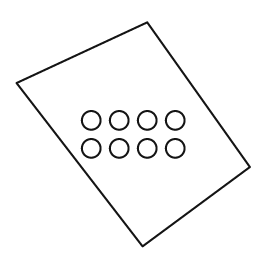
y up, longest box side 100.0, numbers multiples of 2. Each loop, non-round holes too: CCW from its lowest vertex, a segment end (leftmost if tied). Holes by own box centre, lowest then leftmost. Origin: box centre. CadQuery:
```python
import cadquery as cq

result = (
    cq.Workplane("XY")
    .moveTo(4.0, -48.0)
    .lineTo(50.0, -14.0)
    .lineTo(6.0, 48.0)
    .lineTo(-50.0, 22.0)
    .close()
    .moveTo(-18.0, -6.0)
    .circle(4.0)
    .moveTo(-6.0, -6.0)
    .circle(4.0)
    .moveTo(6.0, -6.0)
    .circle(4.0)
    .moveTo(18.0, -6.0)
    .circle(4.0)
    .moveTo(-18.0, 6.0)
    .circle(4.0)
    .moveTo(-6.0, 6.0)
    .circle(4.0)
    .moveTo(6.0, 6.0)
    .circle(4.0)
    .moveTo(18.0, 6.0)
    .circle(4.0)
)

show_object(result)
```